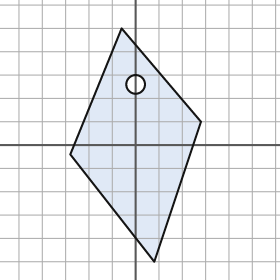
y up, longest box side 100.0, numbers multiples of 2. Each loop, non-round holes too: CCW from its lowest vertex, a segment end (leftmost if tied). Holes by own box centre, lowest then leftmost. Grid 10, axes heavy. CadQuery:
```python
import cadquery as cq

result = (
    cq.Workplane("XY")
    .moveTo(8.0, -50.0)
    .lineTo(28.0, 10.0)
    .lineTo(-6.0, 50.0)
    .lineTo(-28.0, -4.0)
    .close()
    .moveTo(0.0, 26.0)
    .circle(4.0)
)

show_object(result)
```